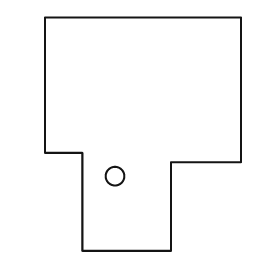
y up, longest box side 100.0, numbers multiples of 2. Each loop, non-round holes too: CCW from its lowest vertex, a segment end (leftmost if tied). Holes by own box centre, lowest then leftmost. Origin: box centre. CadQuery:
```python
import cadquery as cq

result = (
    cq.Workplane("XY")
    .moveTo(-26.0, -50.0)
    .lineTo(12.0, -50.0)
    .lineTo(12.0, -12.0)
    .lineTo(42.0, -12.0)
    .lineTo(42.0, 50.0)
    .lineTo(-42.0, 50.0)
    .lineTo(-42.0, -8.0)
    .lineTo(-26.0, -8.0)
    .close()
    .moveTo(-12.0, -18.0)
    .circle(4.0)
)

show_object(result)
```